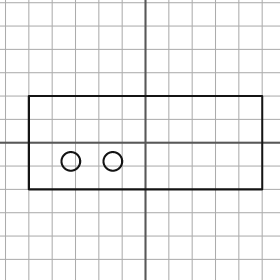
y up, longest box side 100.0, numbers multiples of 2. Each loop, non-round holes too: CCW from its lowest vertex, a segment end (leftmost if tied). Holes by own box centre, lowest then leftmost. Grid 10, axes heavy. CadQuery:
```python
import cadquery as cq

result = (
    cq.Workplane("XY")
    .moveTo(-50.0, -20.0)
    .lineTo(50.0, -20.0)
    .lineTo(50.0, 20.0)
    .lineTo(-50.0, 20.0)
    .close()
    .moveTo(-32.0, -8.0)
    .circle(4.0)
    .moveTo(-14.0, -8.0)
    .circle(4.0)
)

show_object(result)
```